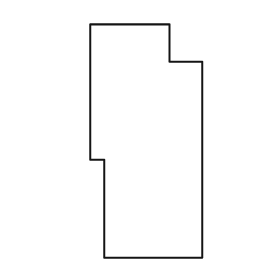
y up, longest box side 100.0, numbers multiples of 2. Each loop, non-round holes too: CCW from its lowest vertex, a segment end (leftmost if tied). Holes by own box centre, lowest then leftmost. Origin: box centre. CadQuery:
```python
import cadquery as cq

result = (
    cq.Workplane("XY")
    .moveTo(-18.0, -50.0)
    .lineTo(24.0, -50.0)
    .lineTo(24.0, 34.0)
    .lineTo(10.0, 34.0)
    .lineTo(10.0, 50.0)
    .lineTo(-24.0, 50.0)
    .lineTo(-24.0, -8.0)
    .lineTo(-18.0, -8.0)
    .close()
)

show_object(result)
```